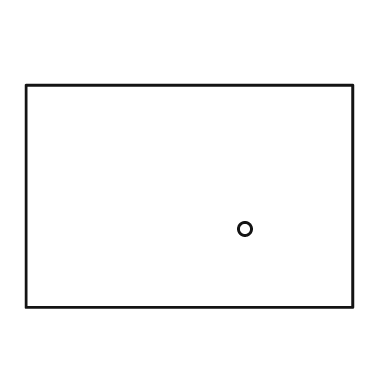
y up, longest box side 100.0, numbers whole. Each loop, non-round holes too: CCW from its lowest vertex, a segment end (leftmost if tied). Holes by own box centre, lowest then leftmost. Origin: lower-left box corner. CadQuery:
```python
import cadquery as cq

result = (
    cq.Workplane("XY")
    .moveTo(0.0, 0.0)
    .lineTo(100.0, 0.0)
    .lineTo(100.0, 68.0)
    .lineTo(0.0, 68.0)
    .close()
    .moveTo(67.0, 24.0)
    .circle(2.0)
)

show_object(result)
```